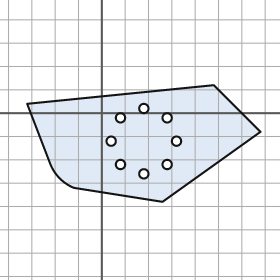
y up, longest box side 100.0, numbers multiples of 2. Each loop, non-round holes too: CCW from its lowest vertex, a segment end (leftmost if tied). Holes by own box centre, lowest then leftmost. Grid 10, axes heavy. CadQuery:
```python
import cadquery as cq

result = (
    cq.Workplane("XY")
    .moveTo(26.0, -38.0)
    .lineTo(68.0, -8.0)
    .lineTo(48.0, 12.0)
    .lineTo(-32.0, 4.0)
    .lineTo(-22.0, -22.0)
    .threePointArc((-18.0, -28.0), (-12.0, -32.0))
    .close()
    .moveTo(18.0, -26.0)
    .circle(2.0)
    .moveTo(8.0, -22.0)
    .circle(2.0)
    .moveTo(28.0, -22.0)
    .circle(2.0)
    .moveTo(4.0, -12.0)
    .circle(2.0)
    .moveTo(32.0, -12.0)
    .circle(2.0)
    .moveTo(8.0, -2.0)
    .circle(2.0)
    .moveTo(28.0, -2.0)
    .circle(2.0)
    .moveTo(18.0, 2.0)
    .circle(2.0)
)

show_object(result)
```